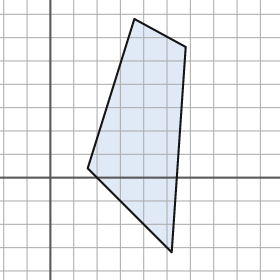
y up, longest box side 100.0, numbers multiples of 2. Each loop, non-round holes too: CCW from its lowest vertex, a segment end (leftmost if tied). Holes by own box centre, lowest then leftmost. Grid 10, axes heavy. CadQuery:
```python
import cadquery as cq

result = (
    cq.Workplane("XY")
    .moveTo(52.0, -32.0)
    .lineTo(58.0, 56.0)
    .lineTo(36.0, 68.0)
    .lineTo(16.0, 4.0)
    .close()
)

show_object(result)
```